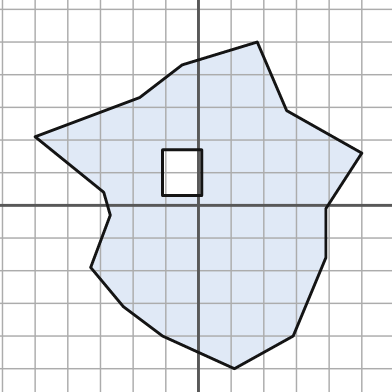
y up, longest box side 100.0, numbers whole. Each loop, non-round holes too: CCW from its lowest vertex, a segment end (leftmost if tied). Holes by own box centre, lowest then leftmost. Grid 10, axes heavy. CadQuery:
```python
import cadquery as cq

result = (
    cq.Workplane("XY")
    .moveTo(11.0, -50.0)
    .lineTo(29.0, -40.0)
    .lineTo(39.0, -16.0)
    .lineTo(39.0, -1.0)
    .lineTo(50.0, 16.0)
    .lineTo(27.0, 29.0)
    .lineTo(18.0, 50.0)
    .lineTo(-5.0, 43.0)
    .lineTo(-18.0, 33.0)
    .lineTo(-50.0, 21.0)
    .lineTo(-29.0, 4.0)
    .lineTo(-27.0, -3.0)
    .lineTo(-33.0, -19.0)
    .lineTo(-23.0, -31.0)
    .lineTo(-11.0, -40.0)
    .close()
    .moveTo(-11.0, 3.0)
    .lineTo(1.0, 3.0)
    .lineTo(1.0, 17.0)
    .lineTo(-11.0, 17.0)
    .close()
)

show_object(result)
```